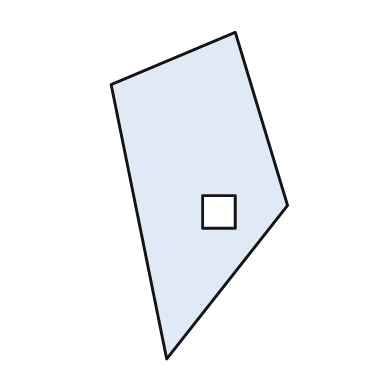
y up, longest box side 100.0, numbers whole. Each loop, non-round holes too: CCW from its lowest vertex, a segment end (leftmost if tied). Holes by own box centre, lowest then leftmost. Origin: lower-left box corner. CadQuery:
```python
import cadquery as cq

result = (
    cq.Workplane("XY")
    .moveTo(17.0, 0.0)
    .lineTo(54.0, 47.0)
    .lineTo(38.0, 100.0)
    .lineTo(0.0, 84.0)
    .close()
    .moveTo(28.0, 40.0)
    .lineTo(38.0, 40.0)
    .lineTo(38.0, 50.0)
    .lineTo(28.0, 50.0)
    .close()
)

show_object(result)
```